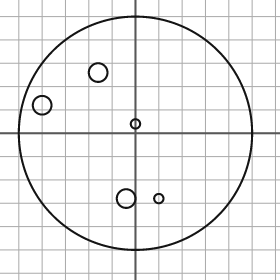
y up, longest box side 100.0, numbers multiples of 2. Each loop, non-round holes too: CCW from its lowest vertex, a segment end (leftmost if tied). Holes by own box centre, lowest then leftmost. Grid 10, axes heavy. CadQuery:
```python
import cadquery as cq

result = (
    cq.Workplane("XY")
    .moveTo(0.0, 0.0)
    .circle(50.0)
    .moveTo(-4.0, -28.0)
    .circle(4.0)
    .moveTo(10.0, -28.0)
    .circle(2.0)
    .moveTo(0.0, 4.0)
    .circle(2.0)
    .moveTo(-40.0, 12.0)
    .circle(4.0)
    .moveTo(-16.0, 26.0)
    .circle(4.0)
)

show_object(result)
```